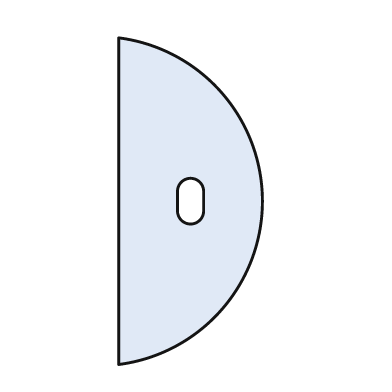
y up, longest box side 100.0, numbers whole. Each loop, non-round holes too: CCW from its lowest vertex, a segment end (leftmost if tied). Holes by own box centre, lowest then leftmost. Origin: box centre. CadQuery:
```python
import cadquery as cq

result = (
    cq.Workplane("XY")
    .moveTo(-22.0, -50.0)
    .threePointArc((22.0, 0.0), (-22.0, 50.0))
    .close()
    .moveTo(-4.0, -3.0)
    .threePointArc((0.0, -7.0), (4.0, -3.0))
    .lineTo(4.0, 3.0)
    .threePointArc((0.0, 7.0), (-4.0, 3.0))
    .close()
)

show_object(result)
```